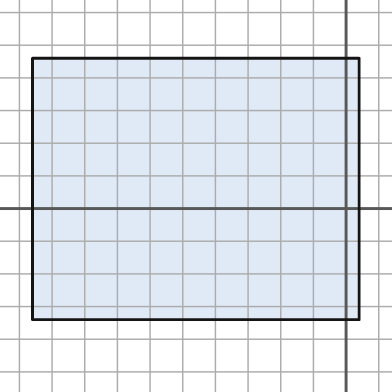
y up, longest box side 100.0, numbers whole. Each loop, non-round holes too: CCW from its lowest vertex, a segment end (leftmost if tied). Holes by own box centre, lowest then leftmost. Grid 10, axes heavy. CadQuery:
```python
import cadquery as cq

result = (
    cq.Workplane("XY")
    .moveTo(-96.0, -34.0)
    .lineTo(4.0, -34.0)
    .lineTo(4.0, 46.0)
    .lineTo(-96.0, 46.0)
    .close()
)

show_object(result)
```